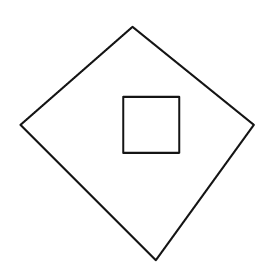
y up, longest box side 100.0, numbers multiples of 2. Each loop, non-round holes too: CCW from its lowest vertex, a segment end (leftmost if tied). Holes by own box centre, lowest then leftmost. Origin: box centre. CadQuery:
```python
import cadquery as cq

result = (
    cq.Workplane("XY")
    .moveTo(8.0, -50.0)
    .lineTo(50.0, 8.0)
    .lineTo(-2.0, 50.0)
    .lineTo(-50.0, 8.0)
    .close()
    .moveTo(-6.0, -4.0)
    .lineTo(18.0, -4.0)
    .lineTo(18.0, 20.0)
    .lineTo(-6.0, 20.0)
    .close()
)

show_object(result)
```